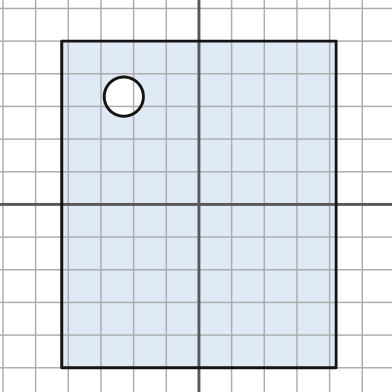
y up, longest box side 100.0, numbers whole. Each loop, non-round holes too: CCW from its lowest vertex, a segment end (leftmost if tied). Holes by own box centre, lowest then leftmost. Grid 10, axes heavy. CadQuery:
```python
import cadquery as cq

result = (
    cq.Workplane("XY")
    .moveTo(-42.0, -50.0)
    .lineTo(42.0, -50.0)
    .lineTo(42.0, 50.0)
    .lineTo(-42.0, 50.0)
    .close()
    .moveTo(-23.0, 33.0)
    .circle(6.0)
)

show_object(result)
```